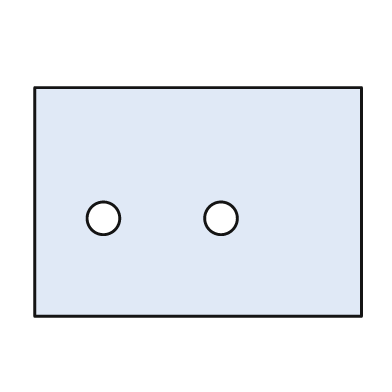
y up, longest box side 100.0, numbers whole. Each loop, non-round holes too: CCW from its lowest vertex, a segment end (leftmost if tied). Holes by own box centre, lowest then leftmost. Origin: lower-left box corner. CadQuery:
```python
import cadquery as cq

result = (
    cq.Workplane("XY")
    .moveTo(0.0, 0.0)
    .lineTo(100.0, 0.0)
    .lineTo(100.0, 70.0)
    .lineTo(0.0, 70.0)
    .close()
    .moveTo(21.0, 30.0)
    .circle(5.0)
    .moveTo(57.0, 30.0)
    .circle(5.0)
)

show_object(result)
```